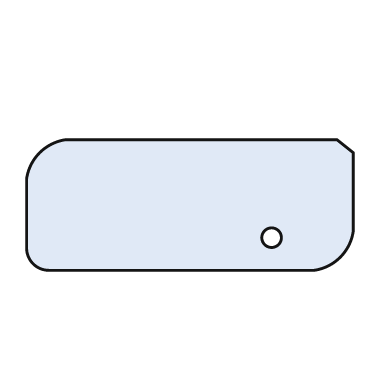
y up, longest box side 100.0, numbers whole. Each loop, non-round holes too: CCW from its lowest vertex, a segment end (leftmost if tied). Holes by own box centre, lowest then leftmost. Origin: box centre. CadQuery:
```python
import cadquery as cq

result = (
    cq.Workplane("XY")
    .moveTo(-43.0, -20.0)
    .lineTo(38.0, -20.0)
    .threePointArc((46.0, -16.0), (50.0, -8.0))
    .lineTo(50.0, 16.0)
    .lineTo(45.0, 20.0)
    .lineTo(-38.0, 20.0)
    .threePointArc((-46.0, 16.0), (-50.0, 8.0))
    .lineTo(-50.0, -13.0)
    .threePointArc((-48.0, -18.0), (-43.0, -20.0))
    .close()
    .moveTo(25.0, -10.0)
    .circle(3.0)
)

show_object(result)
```